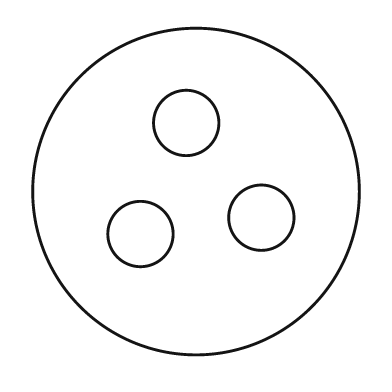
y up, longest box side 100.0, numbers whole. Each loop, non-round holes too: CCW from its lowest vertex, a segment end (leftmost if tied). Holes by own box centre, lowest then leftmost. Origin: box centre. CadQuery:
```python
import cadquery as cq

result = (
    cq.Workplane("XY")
    .moveTo(0.0, 0.0)
    .circle(50.0)
    .moveTo(-17.0, -13.0)
    .circle(10.0)
    .moveTo(20.0, -8.0)
    .circle(10.0)
    .moveTo(-3.0, 21.0)
    .circle(10.0)
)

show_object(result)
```